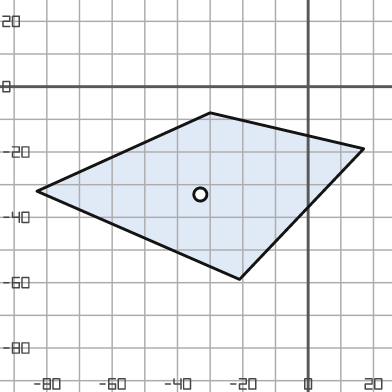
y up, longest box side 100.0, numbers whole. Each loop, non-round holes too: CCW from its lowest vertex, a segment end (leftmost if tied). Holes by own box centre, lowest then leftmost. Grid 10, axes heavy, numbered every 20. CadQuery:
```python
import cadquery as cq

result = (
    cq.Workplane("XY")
    .moveTo(-21.0, -59.0)
    .lineTo(17.0, -19.0)
    .lineTo(-30.0, -8.0)
    .lineTo(-83.0, -32.0)
    .close()
    .moveTo(-33.0, -33.0)
    .circle(2.0)
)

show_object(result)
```